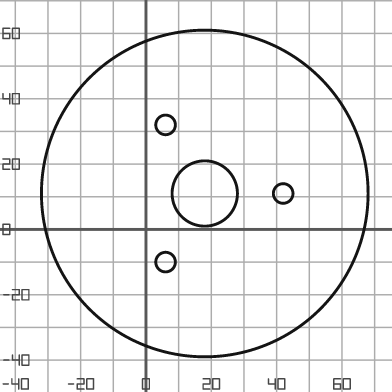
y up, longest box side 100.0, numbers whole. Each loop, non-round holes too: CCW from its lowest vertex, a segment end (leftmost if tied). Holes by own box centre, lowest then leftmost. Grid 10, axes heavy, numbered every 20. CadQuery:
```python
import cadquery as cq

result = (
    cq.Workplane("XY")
    .moveTo(18.0, 11.0)
    .circle(50.0)
    .moveTo(6.0, -10.0)
    .circle(3.0)
    .moveTo(18.0, 11.0)
    .circle(10.0)
    .moveTo(42.0, 11.0)
    .circle(3.0)
    .moveTo(6.0, 32.0)
    .circle(3.0)
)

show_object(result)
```